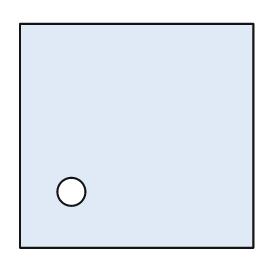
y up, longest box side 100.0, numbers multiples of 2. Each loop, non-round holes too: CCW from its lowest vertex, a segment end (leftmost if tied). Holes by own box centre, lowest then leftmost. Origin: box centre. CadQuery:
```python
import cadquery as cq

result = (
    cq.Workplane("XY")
    .moveTo(-50.0, -48.0)
    .lineTo(50.0, -48.0)
    .lineTo(50.0, 48.0)
    .lineTo(-50.0, 48.0)
    .close()
    .moveTo(-28.0, -24.0)
    .circle(6.0)
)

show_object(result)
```